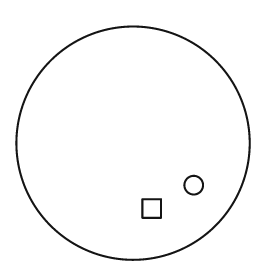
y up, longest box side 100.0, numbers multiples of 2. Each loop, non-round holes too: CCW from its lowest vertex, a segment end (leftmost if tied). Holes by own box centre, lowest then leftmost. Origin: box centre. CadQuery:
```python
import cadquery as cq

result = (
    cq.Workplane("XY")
    .moveTo(0.0, 0.0)
    .circle(50.0)
    .moveTo(4.0, -32.0)
    .lineTo(12.0, -32.0)
    .lineTo(12.0, -24.0)
    .lineTo(4.0, -24.0)
    .close()
    .moveTo(26.0, -18.0)
    .circle(4.0)
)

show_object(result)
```